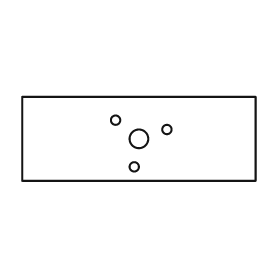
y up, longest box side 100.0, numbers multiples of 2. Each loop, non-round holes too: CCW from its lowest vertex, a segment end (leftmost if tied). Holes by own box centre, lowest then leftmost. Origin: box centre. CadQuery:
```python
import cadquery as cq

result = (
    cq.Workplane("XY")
    .moveTo(-50.0, -18.0)
    .lineTo(50.0, -18.0)
    .lineTo(50.0, 18.0)
    .lineTo(-50.0, 18.0)
    .close()
    .moveTo(-2.0, -12.0)
    .circle(2.0)
    .moveTo(0.0, 0.0)
    .circle(4.0)
    .moveTo(12.0, 4.0)
    .circle(2.0)
    .moveTo(-10.0, 8.0)
    .circle(2.0)
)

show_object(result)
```